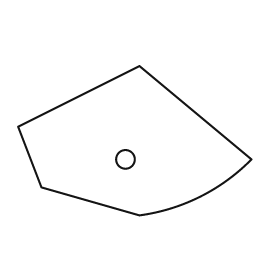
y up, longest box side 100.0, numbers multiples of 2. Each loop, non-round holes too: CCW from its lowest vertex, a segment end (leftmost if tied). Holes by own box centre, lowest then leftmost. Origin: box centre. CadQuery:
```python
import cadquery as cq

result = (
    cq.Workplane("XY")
    .moveTo(2.0, -32.0)
    .threePointArc((28.0, -24.0), (50.0, -8.0))
    .lineTo(2.0, 32.0)
    .lineTo(-50.0, 6.0)
    .lineTo(-40.0, -20.0)
    .close()
    .moveTo(-4.0, -8.0)
    .circle(4.0)
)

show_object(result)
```